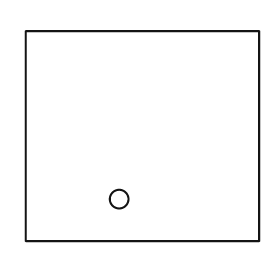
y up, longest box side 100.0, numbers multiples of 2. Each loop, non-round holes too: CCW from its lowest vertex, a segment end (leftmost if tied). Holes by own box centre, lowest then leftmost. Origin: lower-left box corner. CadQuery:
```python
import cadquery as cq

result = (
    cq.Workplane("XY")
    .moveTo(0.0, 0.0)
    .lineTo(100.0, 0.0)
    .lineTo(100.0, 90.0)
    .lineTo(0.0, 90.0)
    .close()
    .moveTo(40.0, 18.0)
    .circle(4.0)
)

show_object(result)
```